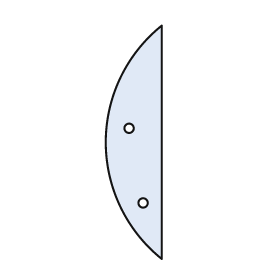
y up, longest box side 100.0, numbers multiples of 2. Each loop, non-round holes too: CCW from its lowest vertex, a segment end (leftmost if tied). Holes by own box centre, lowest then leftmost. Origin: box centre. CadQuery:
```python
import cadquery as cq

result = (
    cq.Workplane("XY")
    .moveTo(12.0, -50.0)
    .lineTo(12.0, 50.0)
    .threePointArc((-12.0, 0.0), (12.0, -50.0))
    .close()
    .moveTo(4.0, -26.0)
    .circle(2.0)
    .moveTo(-2.0, 6.0)
    .circle(2.0)
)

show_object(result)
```